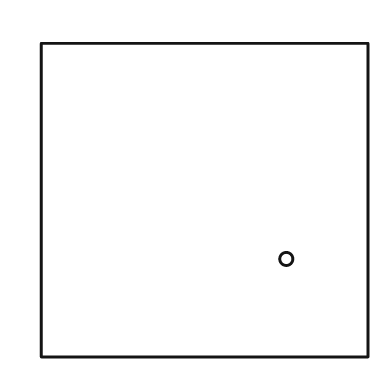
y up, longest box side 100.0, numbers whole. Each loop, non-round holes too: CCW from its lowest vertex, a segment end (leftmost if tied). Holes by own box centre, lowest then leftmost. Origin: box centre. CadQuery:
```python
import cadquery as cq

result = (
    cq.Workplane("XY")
    .moveTo(-50.0, -48.0)
    .lineTo(50.0, -48.0)
    .lineTo(50.0, 48.0)
    .lineTo(-50.0, 48.0)
    .close()
    .moveTo(25.0, -18.0)
    .circle(2.0)
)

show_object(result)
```